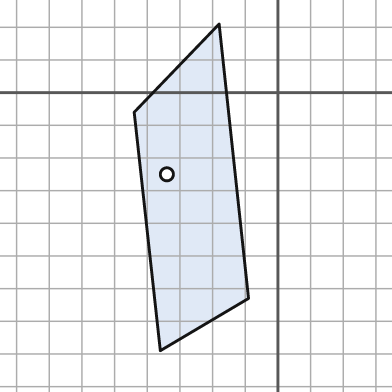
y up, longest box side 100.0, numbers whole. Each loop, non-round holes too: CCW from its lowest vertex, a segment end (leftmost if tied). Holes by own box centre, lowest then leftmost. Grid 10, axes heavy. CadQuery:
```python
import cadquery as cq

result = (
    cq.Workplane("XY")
    .moveTo(-36.0, -79.0)
    .lineTo(-9.0, -63.0)
    .lineTo(-18.0, 21.0)
    .lineTo(-44.0, -6.0)
    .close()
    .moveTo(-34.0, -25.0)
    .circle(2.0)
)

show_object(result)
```